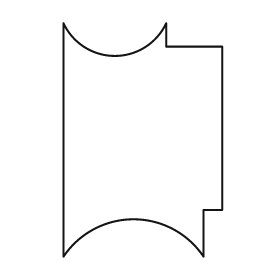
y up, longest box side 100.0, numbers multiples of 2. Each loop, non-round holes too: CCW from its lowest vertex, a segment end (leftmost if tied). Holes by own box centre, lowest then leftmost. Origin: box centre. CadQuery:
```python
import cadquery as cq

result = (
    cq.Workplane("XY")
    .moveTo(-34.0, -50.0)
    .threePointArc((-4.0, -34.0), (26.0, -50.0))
    .lineTo(26.0, -30.0)
    .lineTo(34.0, -30.0)
    .lineTo(34.0, 40.0)
    .lineTo(10.0, 40.0)
    .lineTo(10.0, 50.0)
    .threePointArc((-12.0, 36.0), (-34.0, 50.0))
    .close()
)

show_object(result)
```